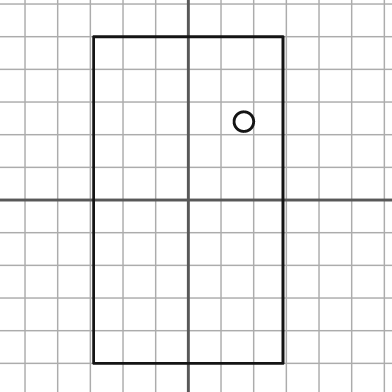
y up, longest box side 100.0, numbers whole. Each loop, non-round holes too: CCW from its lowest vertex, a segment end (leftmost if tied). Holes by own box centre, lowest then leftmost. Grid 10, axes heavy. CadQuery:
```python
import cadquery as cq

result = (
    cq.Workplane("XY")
    .moveTo(-29.0, -50.0)
    .lineTo(29.0, -50.0)
    .lineTo(29.0, 50.0)
    .lineTo(-29.0, 50.0)
    .close()
    .moveTo(17.0, 24.0)
    .circle(3.0)
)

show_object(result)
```